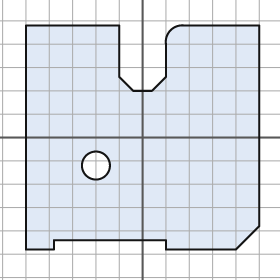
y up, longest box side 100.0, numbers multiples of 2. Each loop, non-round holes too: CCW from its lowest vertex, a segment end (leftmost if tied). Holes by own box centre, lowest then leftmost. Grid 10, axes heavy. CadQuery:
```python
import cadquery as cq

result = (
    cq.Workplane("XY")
    .moveTo(-50.0, -48.0)
    .lineTo(-38.0, -48.0)
    .lineTo(-38.0, -44.0)
    .lineTo(10.0, -44.0)
    .lineTo(10.0, -48.0)
    .lineTo(40.0, -48.0)
    .lineTo(50.0, -38.0)
    .lineTo(50.0, 48.0)
    .lineTo(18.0, 48.0)
    .threePointArc((12.0, 46.0), (10.0, 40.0))
    .lineTo(10.0, 26.0)
    .lineTo(4.0, 20.0)
    .lineTo(-4.0, 20.0)
    .lineTo(-10.0, 26.0)
    .lineTo(-10.0, 48.0)
    .lineTo(-50.0, 48.0)
    .close()
    .moveTo(-20.0, -12.0)
    .circle(6.0)
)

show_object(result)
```